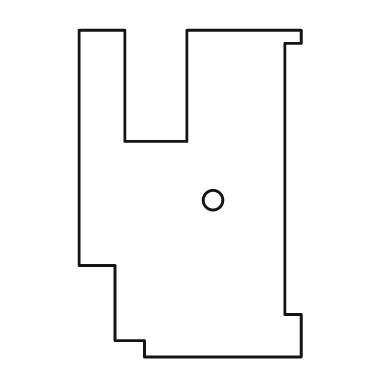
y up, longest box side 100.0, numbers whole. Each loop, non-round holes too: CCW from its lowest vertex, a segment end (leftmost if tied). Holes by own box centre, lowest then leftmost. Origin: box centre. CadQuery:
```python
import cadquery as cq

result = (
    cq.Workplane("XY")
    .moveTo(-14.0, -50.0)
    .lineTo(34.0, -50.0)
    .lineTo(34.0, -37.0)
    .lineTo(29.0, -37.0)
    .lineTo(29.0, 46.0)
    .lineTo(34.0, 46.0)
    .lineTo(34.0, 50.0)
    .lineTo(-1.0, 50.0)
    .lineTo(-1.0, 16.0)
    .lineTo(-20.0, 16.0)
    .lineTo(-20.0, 50.0)
    .lineTo(-34.0, 50.0)
    .lineTo(-34.0, -22.0)
    .lineTo(-23.0, -22.0)
    .lineTo(-23.0, -45.0)
    .lineTo(-14.0, -45.0)
    .close()
    .moveTo(7.0, -2.0)
    .circle(3.0)
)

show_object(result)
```